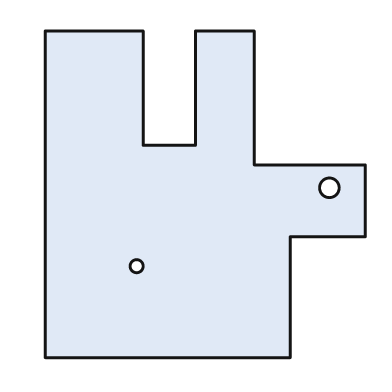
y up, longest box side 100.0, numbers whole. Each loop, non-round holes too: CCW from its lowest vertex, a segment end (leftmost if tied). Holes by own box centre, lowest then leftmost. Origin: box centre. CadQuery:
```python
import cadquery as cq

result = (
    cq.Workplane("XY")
    .moveTo(-49.0, -50.0)
    .lineTo(26.0, -50.0)
    .lineTo(26.0, -13.0)
    .lineTo(49.0, -13.0)
    .lineTo(49.0, 9.0)
    .lineTo(15.0, 9.0)
    .lineTo(15.0, 50.0)
    .lineTo(-3.0, 50.0)
    .lineTo(-3.0, 15.0)
    .lineTo(-19.0, 15.0)
    .lineTo(-19.0, 50.0)
    .lineTo(-49.0, 50.0)
    .close()
    .moveTo(-21.0, -22.0)
    .circle(2.0)
    .moveTo(38.0, 2.0)
    .circle(3.0)
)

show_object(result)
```